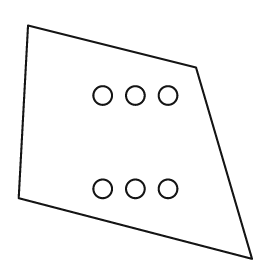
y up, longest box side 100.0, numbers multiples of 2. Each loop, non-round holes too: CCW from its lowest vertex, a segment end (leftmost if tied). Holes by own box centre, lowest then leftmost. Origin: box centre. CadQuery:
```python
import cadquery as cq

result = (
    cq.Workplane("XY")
    .moveTo(50.0, -50.0)
    .lineTo(26.0, 32.0)
    .lineTo(-46.0, 50.0)
    .lineTo(-50.0, -24.0)
    .close()
    .moveTo(-14.0, -20.0)
    .circle(4.0)
    .moveTo(0.0, -20.0)
    .circle(4.0)
    .moveTo(14.0, -20.0)
    .circle(4.0)
    .moveTo(-14.0, 20.0)
    .circle(4.0)
    .moveTo(0.0, 20.0)
    .circle(4.0)
    .moveTo(14.0, 20.0)
    .circle(4.0)
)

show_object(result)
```